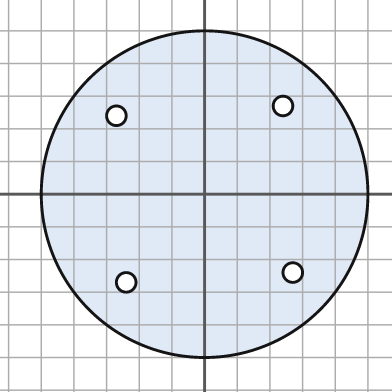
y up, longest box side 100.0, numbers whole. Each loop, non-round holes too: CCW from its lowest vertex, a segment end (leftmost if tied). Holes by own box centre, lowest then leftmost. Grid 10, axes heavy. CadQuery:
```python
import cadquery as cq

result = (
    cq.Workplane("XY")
    .moveTo(0.0, 0.0)
    .circle(50.0)
    .moveTo(-24.0, -27.0)
    .circle(3.0)
    .moveTo(27.0, -24.0)
    .circle(3.0)
    .moveTo(-27.0, 24.0)
    .circle(3.0)
    .moveTo(24.0, 27.0)
    .circle(3.0)
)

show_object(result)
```